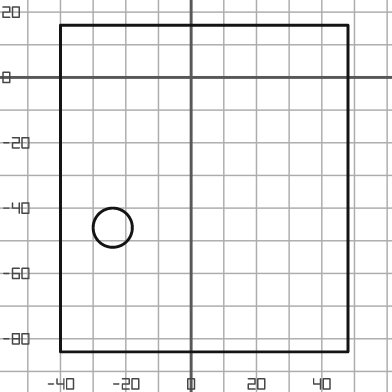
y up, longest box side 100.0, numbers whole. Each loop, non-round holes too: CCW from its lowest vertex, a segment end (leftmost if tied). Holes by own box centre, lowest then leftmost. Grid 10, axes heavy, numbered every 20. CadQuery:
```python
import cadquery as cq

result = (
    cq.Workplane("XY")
    .moveTo(-40.0, -84.0)
    .lineTo(48.0, -84.0)
    .lineTo(48.0, 16.0)
    .lineTo(-40.0, 16.0)
    .close()
    .moveTo(-24.0, -46.0)
    .circle(6.0)
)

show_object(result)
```